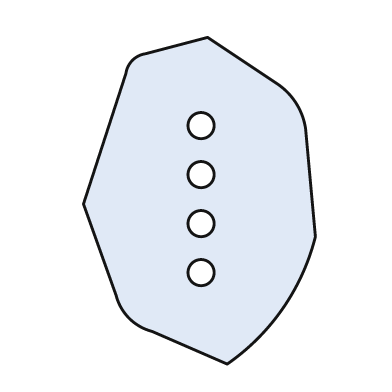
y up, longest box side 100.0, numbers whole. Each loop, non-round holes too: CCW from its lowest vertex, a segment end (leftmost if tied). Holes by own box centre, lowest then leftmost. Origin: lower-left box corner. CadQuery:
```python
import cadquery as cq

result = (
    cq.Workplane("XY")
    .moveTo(44.0, 0.0)
    .threePointArc((61.0, 17.0), (71.0, 39.0))
    .lineTo(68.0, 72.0)
    .threePointArc((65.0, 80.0), (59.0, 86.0))
    .lineTo(38.0, 100.0)
    .lineTo(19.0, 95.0)
    .threePointArc((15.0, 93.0), (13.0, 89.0))
    .lineTo(0.0, 49.0)
    .lineTo(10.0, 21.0)
    .threePointArc((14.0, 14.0), (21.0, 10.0))
    .close()
    .moveTo(36.0, 28.0)
    .circle(4.0)
    .moveTo(36.0, 43.0)
    .circle(4.0)
    .moveTo(36.0, 58.0)
    .circle(4.0)
    .moveTo(36.0, 73.0)
    .circle(4.0)
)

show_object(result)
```